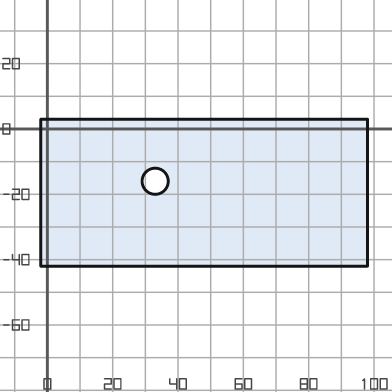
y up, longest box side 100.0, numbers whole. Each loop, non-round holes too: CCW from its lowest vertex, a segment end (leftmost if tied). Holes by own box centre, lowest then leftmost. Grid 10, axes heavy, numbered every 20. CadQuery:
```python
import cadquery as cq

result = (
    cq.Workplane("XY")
    .moveTo(-2.0, -42.0)
    .lineTo(98.0, -42.0)
    .lineTo(98.0, 3.0)
    .lineTo(-2.0, 3.0)
    .close()
    .moveTo(33.0, -16.0)
    .circle(4.0)
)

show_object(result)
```